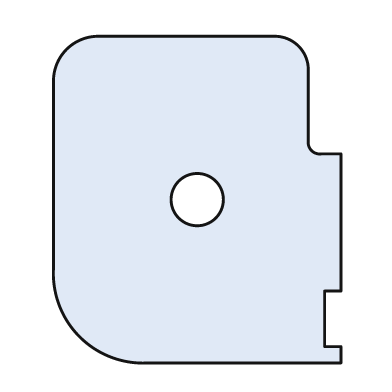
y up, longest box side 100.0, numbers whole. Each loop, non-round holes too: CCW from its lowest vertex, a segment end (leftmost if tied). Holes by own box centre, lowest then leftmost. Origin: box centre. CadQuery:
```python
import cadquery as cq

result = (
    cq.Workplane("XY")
    .moveTo(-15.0, -50.0)
    .lineTo(44.0, -50.0)
    .lineTo(44.0, -45.0)
    .lineTo(39.0, -45.0)
    .lineTo(39.0, -28.0)
    .lineTo(44.0, -28.0)
    .lineTo(44.0, 14.0)
    .lineTo(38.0, 14.0)
    .threePointArc((35.0, 15.0), (34.0, 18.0))
    .lineTo(34.0, 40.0)
    .threePointArc((31.0, 47.0), (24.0, 50.0))
    .lineTo(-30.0, 50.0)
    .threePointArc((-40.0, 46.0), (-44.0, 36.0))
    .lineTo(-44.0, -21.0)
    .threePointArc((-36.0, -42.0), (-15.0, -50.0))
    .close()
    .moveTo(0.0, 0.0)
    .circle(8.0)
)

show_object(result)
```